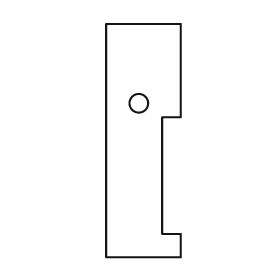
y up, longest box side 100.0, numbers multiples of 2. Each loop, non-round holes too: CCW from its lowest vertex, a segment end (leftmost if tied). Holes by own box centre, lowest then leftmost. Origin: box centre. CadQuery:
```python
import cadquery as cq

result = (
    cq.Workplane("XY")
    .moveTo(-16.0, -50.0)
    .lineTo(16.0, -50.0)
    .lineTo(16.0, -40.0)
    .lineTo(8.0, -40.0)
    .lineTo(8.0, 10.0)
    .lineTo(16.0, 10.0)
    .lineTo(16.0, 50.0)
    .lineTo(-16.0, 50.0)
    .close()
    .moveTo(-2.0, 16.0)
    .circle(4.0)
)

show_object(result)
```